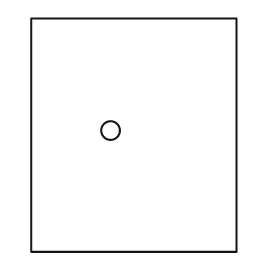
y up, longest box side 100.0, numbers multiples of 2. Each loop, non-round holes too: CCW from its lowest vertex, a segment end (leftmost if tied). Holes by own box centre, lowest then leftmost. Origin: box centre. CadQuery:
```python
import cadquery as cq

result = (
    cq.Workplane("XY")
    .moveTo(-44.0, -50.0)
    .lineTo(44.0, -50.0)
    .lineTo(44.0, 50.0)
    .lineTo(-44.0, 50.0)
    .close()
    .moveTo(-10.0, 2.0)
    .circle(4.0)
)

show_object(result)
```